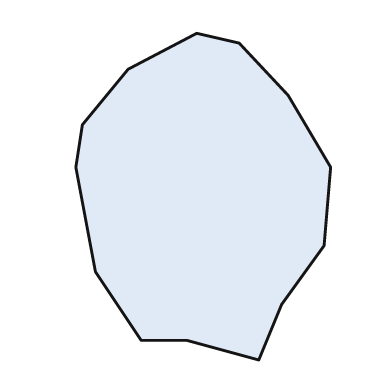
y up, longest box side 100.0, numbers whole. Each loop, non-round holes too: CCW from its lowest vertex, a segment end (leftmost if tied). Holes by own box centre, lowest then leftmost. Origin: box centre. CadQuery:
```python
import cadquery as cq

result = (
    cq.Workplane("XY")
    .moveTo(17.0, -50.0)
    .lineTo(24.0, -33.0)
    .lineTo(37.0, -15.0)
    .lineTo(39.0, 9.0)
    .lineTo(26.0, 31.0)
    .lineTo(11.0, 47.0)
    .lineTo(-2.0, 50.0)
    .lineTo(-23.0, 39.0)
    .lineTo(-37.0, 22.0)
    .lineTo(-39.0, 9.0)
    .lineTo(-33.0, -23.0)
    .lineTo(-19.0, -44.0)
    .lineTo(-5.0, -44.0)
    .close()
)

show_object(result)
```